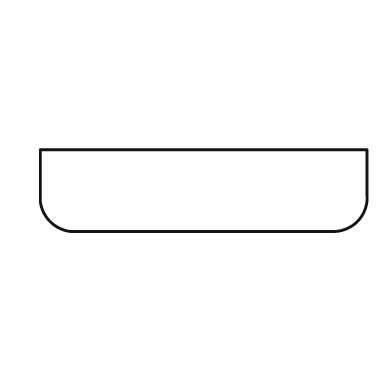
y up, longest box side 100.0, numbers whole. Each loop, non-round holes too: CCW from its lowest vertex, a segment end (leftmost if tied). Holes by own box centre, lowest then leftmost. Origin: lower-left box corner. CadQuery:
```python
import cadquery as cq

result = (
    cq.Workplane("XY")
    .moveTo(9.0, 0.0)
    .lineTo(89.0, 0.0)
    .threePointArc((97.0, 3.0), (100.0, 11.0))
    .lineTo(100.0, 25.0)
    .lineTo(0.0, 25.0)
    .lineTo(0.0, 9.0)
    .threePointArc((3.0, 3.0), (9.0, 0.0))
    .close()
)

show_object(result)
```